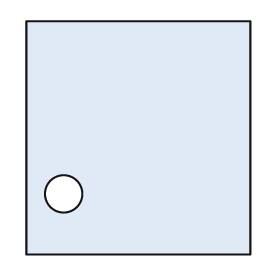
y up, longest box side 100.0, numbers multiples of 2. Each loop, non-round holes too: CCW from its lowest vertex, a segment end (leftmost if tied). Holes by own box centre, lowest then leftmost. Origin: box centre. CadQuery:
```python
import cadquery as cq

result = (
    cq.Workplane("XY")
    .moveTo(-48.0, -50.0)
    .lineTo(48.0, -50.0)
    .lineTo(48.0, 50.0)
    .lineTo(-48.0, 50.0)
    .close()
    .moveTo(-32.0, -24.0)
    .circle(8.0)
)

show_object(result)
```